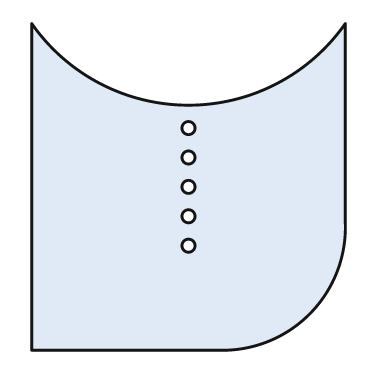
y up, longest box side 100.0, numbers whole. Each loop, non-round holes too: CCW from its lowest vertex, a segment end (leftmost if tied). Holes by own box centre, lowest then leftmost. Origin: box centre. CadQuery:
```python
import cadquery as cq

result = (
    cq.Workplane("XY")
    .moveTo(-48.0, -50.0)
    .lineTo(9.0, -50.0)
    .threePointArc((37.0, -39.0), (48.0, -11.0))
    .lineTo(48.0, 50.0)
    .threePointArc((0.0, 25.0), (-48.0, 50.0))
    .close()
    .moveTo(0.0, -18.0)
    .circle(2.0)
    .moveTo(0.0, -9.0)
    .circle(2.0)
    .moveTo(0.0, 0.0)
    .circle(2.0)
    .moveTo(0.0, 9.0)
    .circle(2.0)
    .moveTo(0.0, 18.0)
    .circle(2.0)
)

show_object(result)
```